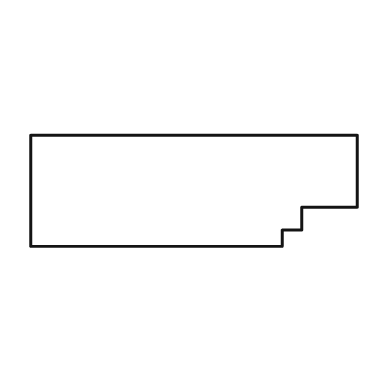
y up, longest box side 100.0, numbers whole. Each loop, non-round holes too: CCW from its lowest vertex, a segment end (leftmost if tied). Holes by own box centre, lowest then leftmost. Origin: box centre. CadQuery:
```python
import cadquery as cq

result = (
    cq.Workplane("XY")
    .moveTo(-50.0, -17.0)
    .lineTo(27.0, -17.0)
    .lineTo(27.0, -12.0)
    .lineTo(33.0, -12.0)
    .lineTo(33.0, -5.0)
    .lineTo(50.0, -5.0)
    .lineTo(50.0, 17.0)
    .lineTo(-50.0, 17.0)
    .close()
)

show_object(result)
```